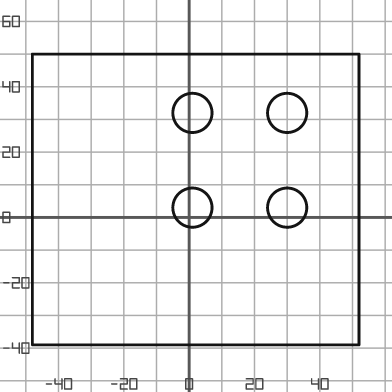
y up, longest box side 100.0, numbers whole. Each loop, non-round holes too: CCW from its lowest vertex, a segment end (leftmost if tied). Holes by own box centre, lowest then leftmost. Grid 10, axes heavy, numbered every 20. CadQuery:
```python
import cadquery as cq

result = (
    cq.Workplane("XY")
    .moveTo(-48.0, -39.0)
    .lineTo(52.0, -39.0)
    .lineTo(52.0, 50.0)
    .lineTo(-48.0, 50.0)
    .close()
    .moveTo(1.0, 3.0)
    .circle(6.0)
    .moveTo(30.0, 3.0)
    .circle(6.0)
    .moveTo(1.0, 32.0)
    .circle(6.0)
    .moveTo(30.0, 32.0)
    .circle(6.0)
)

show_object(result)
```